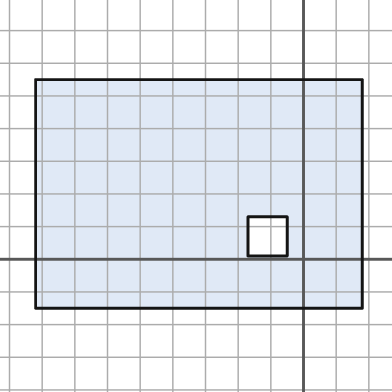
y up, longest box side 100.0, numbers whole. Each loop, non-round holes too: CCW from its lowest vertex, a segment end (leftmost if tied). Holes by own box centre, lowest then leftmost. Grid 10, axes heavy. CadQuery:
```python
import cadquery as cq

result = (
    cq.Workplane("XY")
    .moveTo(-82.0, -15.0)
    .lineTo(18.0, -15.0)
    .lineTo(18.0, 55.0)
    .lineTo(-82.0, 55.0)
    .close()
    .moveTo(-17.0, 1.0)
    .lineTo(-5.0, 1.0)
    .lineTo(-5.0, 13.0)
    .lineTo(-17.0, 13.0)
    .close()
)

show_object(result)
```